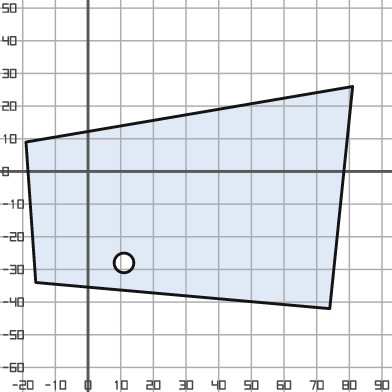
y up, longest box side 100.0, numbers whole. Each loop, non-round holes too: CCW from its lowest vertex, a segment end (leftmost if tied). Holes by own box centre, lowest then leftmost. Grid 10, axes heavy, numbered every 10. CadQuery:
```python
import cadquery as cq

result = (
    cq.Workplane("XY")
    .moveTo(74.0, -42.0)
    .lineTo(81.0, 26.0)
    .lineTo(-19.0, 9.0)
    .lineTo(-16.0, -34.0)
    .close()
    .moveTo(11.0, -28.0)
    .circle(3.0)
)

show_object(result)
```